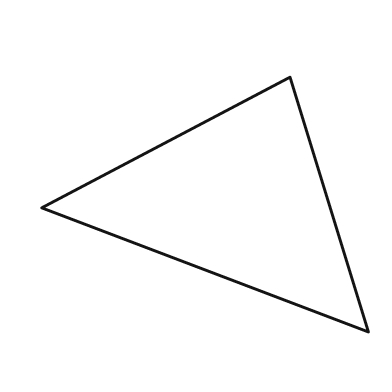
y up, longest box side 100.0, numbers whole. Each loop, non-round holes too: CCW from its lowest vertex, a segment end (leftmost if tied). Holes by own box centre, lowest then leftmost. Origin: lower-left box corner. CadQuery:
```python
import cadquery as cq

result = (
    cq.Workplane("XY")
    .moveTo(100.0, 0.0)
    .lineTo(76.0, 78.0)
    .lineTo(0.0, 38.0)
    .close()
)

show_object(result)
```